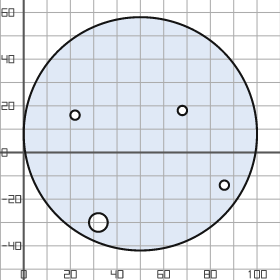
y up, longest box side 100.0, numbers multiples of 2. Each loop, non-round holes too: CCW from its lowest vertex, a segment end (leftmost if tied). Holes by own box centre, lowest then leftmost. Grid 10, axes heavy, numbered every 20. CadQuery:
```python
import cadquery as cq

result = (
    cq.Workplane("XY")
    .moveTo(50.0, 8.0)
    .circle(50.0)
    .moveTo(32.0, -30.0)
    .circle(4.0)
    .moveTo(86.0, -14.0)
    .circle(2.0)
    .moveTo(22.0, 16.0)
    .circle(2.0)
    .moveTo(68.0, 18.0)
    .circle(2.0)
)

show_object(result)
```